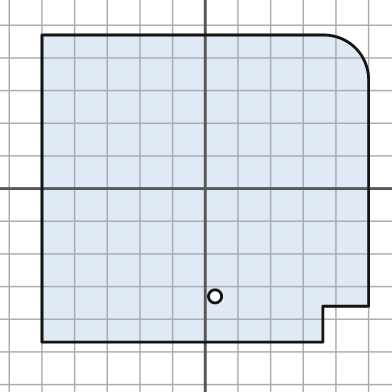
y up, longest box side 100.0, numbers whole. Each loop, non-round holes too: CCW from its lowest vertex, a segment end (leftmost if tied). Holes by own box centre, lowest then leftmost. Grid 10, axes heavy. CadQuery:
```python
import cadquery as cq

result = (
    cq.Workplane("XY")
    .moveTo(-50.0, -47.0)
    .lineTo(36.0, -47.0)
    .lineTo(36.0, -36.0)
    .lineTo(50.0, -36.0)
    .lineTo(50.0, 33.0)
    .threePointArc((46.0, 43.0), (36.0, 47.0))
    .lineTo(-50.0, 47.0)
    .close()
    .moveTo(3.0, -33.0)
    .circle(2.0)
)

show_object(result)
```